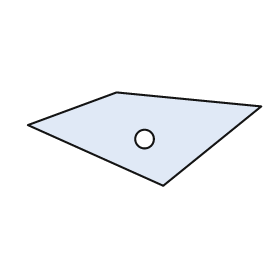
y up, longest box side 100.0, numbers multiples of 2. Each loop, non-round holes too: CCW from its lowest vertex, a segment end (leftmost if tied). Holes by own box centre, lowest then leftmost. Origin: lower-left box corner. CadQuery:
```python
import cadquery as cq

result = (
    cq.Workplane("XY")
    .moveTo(58.0, 0.0)
    .lineTo(100.0, 34.0)
    .lineTo(38.0, 40.0)
    .lineTo(0.0, 26.0)
    .close()
    .moveTo(50.0, 20.0)
    .circle(4.0)
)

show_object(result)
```